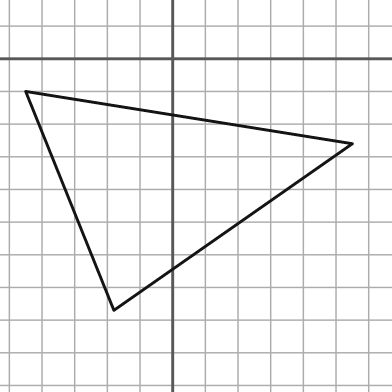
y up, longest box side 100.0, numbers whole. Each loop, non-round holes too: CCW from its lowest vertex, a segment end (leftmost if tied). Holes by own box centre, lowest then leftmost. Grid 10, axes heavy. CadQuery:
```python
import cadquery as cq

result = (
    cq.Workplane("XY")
    .moveTo(-18.0, -77.0)
    .lineTo(55.0, -26.0)
    .lineTo(-45.0, -10.0)
    .close()
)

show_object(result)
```